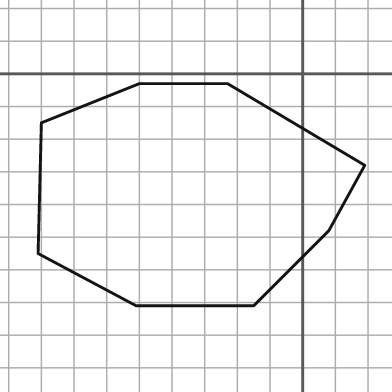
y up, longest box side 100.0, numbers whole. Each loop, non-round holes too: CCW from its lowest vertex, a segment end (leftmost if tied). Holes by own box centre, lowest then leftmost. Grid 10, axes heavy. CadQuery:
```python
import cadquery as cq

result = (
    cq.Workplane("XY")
    .moveTo(-51.0, -71.0)
    .lineTo(-15.0, -71.0)
    .lineTo(8.0, -48.0)
    .lineTo(19.0, -28.0)
    .lineTo(-23.0, -3.0)
    .lineTo(-50.0, -3.0)
    .lineTo(-80.0, -15.0)
    .lineTo(-81.0, -55.0)
    .close()
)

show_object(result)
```